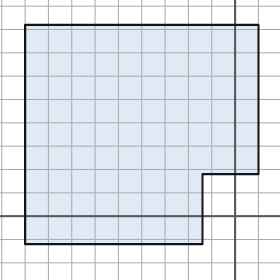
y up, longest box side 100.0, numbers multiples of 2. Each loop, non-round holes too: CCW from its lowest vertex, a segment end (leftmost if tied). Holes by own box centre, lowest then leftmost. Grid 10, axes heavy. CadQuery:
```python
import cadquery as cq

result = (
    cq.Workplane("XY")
    .moveTo(-90.0, -12.0)
    .lineTo(-14.0, -12.0)
    .lineTo(-14.0, 18.0)
    .lineTo(10.0, 18.0)
    .lineTo(10.0, 82.0)
    .lineTo(-90.0, 82.0)
    .close()
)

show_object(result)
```